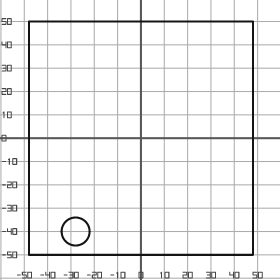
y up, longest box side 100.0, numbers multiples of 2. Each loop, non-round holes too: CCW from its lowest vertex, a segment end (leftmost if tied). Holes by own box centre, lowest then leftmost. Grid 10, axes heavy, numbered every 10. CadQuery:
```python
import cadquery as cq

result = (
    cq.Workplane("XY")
    .moveTo(-48.0, -50.0)
    .lineTo(48.0, -50.0)
    .lineTo(48.0, 50.0)
    .lineTo(-48.0, 50.0)
    .close()
    .moveTo(-28.0, -40.0)
    .circle(6.0)
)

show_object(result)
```